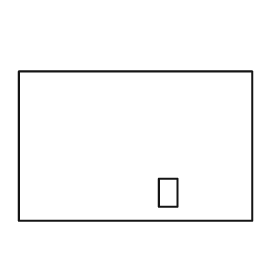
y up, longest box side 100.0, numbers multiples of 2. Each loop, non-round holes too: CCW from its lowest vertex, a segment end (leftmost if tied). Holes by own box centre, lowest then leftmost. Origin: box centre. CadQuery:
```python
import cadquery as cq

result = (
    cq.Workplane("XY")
    .moveTo(-50.0, -32.0)
    .lineTo(50.0, -32.0)
    .lineTo(50.0, 32.0)
    .lineTo(-50.0, 32.0)
    .close()
    .moveTo(10.0, -26.0)
    .lineTo(18.0, -26.0)
    .lineTo(18.0, -14.0)
    .lineTo(10.0, -14.0)
    .close()
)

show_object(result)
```